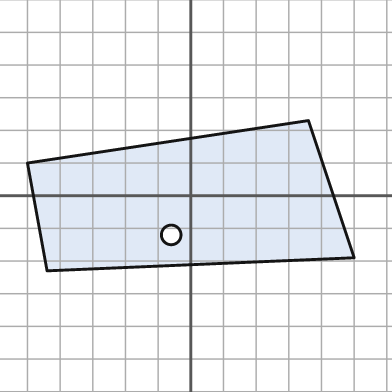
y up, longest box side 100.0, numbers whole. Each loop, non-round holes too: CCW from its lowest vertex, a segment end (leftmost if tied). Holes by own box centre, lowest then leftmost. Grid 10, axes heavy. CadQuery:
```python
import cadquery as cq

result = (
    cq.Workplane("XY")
    .moveTo(-44.0, -23.0)
    .lineTo(50.0, -19.0)
    .lineTo(36.0, 23.0)
    .lineTo(-50.0, 10.0)
    .close()
    .moveTo(-6.0, -12.0)
    .circle(3.0)
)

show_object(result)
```